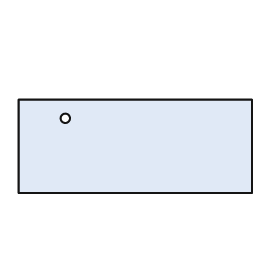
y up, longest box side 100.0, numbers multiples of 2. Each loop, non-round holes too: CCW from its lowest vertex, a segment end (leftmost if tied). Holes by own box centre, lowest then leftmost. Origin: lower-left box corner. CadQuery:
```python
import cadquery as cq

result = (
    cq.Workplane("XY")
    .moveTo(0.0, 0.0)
    .lineTo(100.0, 0.0)
    .lineTo(100.0, 40.0)
    .lineTo(0.0, 40.0)
    .close()
    .moveTo(20.0, 32.0)
    .circle(2.0)
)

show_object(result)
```